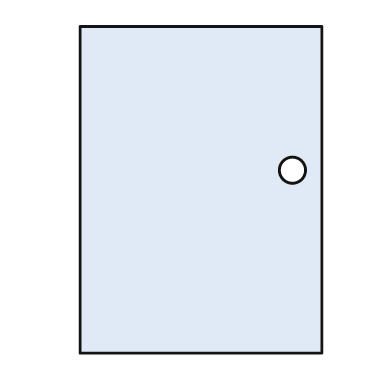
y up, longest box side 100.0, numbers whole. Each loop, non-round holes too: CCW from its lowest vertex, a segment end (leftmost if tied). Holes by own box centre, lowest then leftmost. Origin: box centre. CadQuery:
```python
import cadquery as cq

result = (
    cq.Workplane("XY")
    .moveTo(-37.0, -50.0)
    .lineTo(37.0, -50.0)
    .lineTo(37.0, 50.0)
    .lineTo(-37.0, 50.0)
    .close()
    .moveTo(28.0, 6.0)
    .circle(4.0)
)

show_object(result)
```